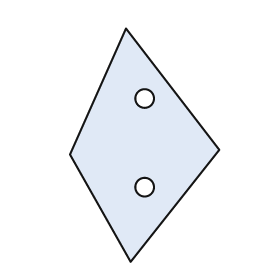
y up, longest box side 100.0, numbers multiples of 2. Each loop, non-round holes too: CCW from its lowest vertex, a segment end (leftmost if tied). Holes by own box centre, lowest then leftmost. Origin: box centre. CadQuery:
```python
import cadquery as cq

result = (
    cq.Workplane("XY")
    .moveTo(-6.0, -50.0)
    .lineTo(32.0, -2.0)
    .lineTo(-8.0, 50.0)
    .lineTo(-32.0, -4.0)
    .close()
    .moveTo(0.0, -18.0)
    .circle(4.0)
    .moveTo(0.0, 20.0)
    .circle(4.0)
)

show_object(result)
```